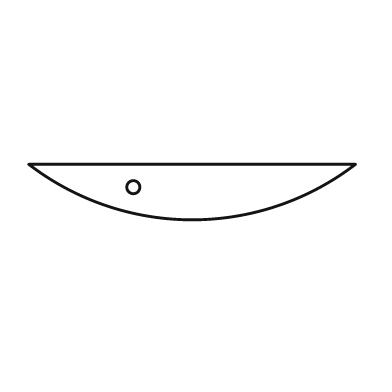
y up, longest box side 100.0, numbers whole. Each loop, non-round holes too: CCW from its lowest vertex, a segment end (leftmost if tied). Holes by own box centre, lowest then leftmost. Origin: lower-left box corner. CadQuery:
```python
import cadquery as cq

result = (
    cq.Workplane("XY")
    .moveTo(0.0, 17.0)
    .threePointArc((50.0, 0.0), (100.0, 17.0))
    .close()
    .moveTo(32.0, 10.0)
    .circle(2.0)
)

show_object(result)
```